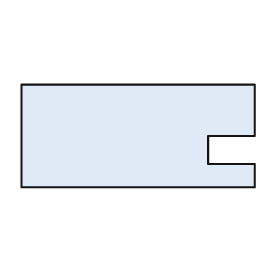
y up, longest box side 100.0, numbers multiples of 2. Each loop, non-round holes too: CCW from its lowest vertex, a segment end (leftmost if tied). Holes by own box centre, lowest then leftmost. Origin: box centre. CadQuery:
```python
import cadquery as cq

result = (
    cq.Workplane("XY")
    .moveTo(-50.0, -22.0)
    .lineTo(50.0, -22.0)
    .lineTo(50.0, -12.0)
    .lineTo(30.0, -12.0)
    .lineTo(30.0, 0.0)
    .lineTo(50.0, 0.0)
    .lineTo(50.0, 22.0)
    .lineTo(-50.0, 22.0)
    .close()
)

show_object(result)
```